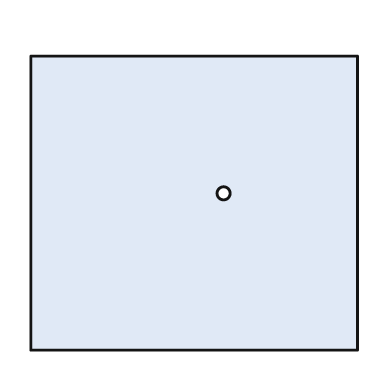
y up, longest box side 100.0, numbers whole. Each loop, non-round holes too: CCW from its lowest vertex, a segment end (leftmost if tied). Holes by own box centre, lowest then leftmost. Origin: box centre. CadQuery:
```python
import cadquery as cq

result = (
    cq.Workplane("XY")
    .moveTo(-50.0, -45.0)
    .lineTo(50.0, -45.0)
    .lineTo(50.0, 45.0)
    .lineTo(-50.0, 45.0)
    .close()
    .moveTo(9.0, 3.0)
    .circle(2.0)
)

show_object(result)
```